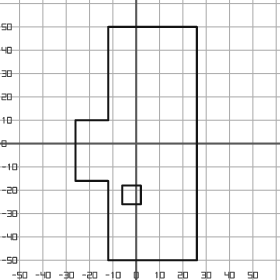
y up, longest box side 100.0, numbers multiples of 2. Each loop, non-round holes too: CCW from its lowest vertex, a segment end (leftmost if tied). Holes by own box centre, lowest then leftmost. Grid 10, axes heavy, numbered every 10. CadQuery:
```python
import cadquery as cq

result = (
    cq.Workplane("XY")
    .moveTo(-12.0, -50.0)
    .lineTo(26.0, -50.0)
    .lineTo(26.0, 50.0)
    .lineTo(-12.0, 50.0)
    .lineTo(-12.0, 10.0)
    .lineTo(-26.0, 10.0)
    .lineTo(-26.0, -16.0)
    .lineTo(-12.0, -16.0)
    .close()
    .moveTo(-6.0, -26.0)
    .lineTo(2.0, -26.0)
    .lineTo(2.0, -18.0)
    .lineTo(-6.0, -18.0)
    .close()
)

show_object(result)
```